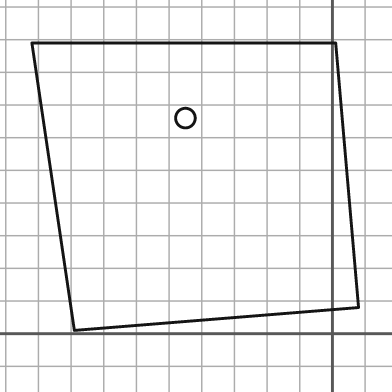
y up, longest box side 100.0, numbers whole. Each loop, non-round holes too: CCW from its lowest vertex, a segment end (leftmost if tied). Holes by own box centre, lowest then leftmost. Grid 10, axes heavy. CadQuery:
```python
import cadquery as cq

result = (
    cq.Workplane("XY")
    .moveTo(-79.0, 1.0)
    .lineTo(8.0, 8.0)
    .lineTo(1.0, 89.0)
    .lineTo(-92.0, 89.0)
    .close()
    .moveTo(-45.0, 66.0)
    .circle(3.0)
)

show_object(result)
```